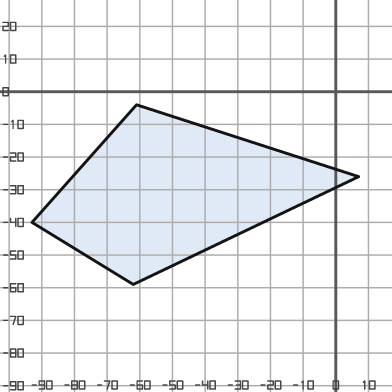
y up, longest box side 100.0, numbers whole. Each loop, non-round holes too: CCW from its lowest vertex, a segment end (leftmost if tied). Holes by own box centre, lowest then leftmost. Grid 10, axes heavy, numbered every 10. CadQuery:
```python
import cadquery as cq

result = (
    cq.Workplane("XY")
    .moveTo(-62.0, -59.0)
    .lineTo(7.0, -26.0)
    .lineTo(-61.0, -4.0)
    .lineTo(-93.0, -40.0)
    .close()
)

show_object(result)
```